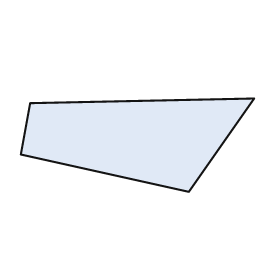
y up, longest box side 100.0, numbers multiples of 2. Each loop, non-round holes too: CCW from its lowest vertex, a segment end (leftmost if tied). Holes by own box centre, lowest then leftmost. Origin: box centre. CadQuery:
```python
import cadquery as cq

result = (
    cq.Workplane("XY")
    .moveTo(22.0, -20.0)
    .lineTo(50.0, 20.0)
    .lineTo(-46.0, 18.0)
    .lineTo(-50.0, -4.0)
    .close()
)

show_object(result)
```